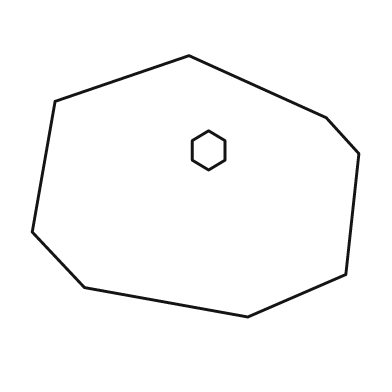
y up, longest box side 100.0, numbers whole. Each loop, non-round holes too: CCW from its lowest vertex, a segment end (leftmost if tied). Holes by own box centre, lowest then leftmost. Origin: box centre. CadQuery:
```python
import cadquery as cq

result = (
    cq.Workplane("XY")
    .moveTo(16.0, -40.0)
    .lineTo(46.0, -27.0)
    .lineTo(50.0, 10.0)
    .lineTo(40.0, 21.0)
    .lineTo(-2.0, 40.0)
    .lineTo(-43.0, 26.0)
    .lineTo(-50.0, -14.0)
    .lineTo(-34.0, -31.0)
    .close()
    .moveTo(4.0, 5.0)
    .lineTo(9.0, 8.0)
    .lineTo(9.0, 14.0)
    .lineTo(4.0, 17.0)
    .lineTo(-1.0, 14.0)
    .lineTo(-1.0, 8.0)
    .close()
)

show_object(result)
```